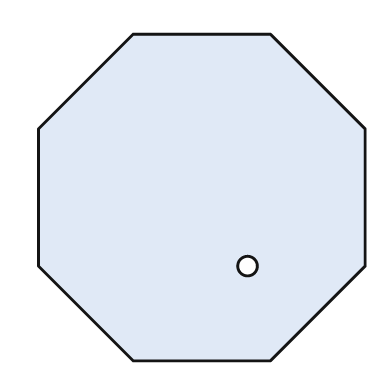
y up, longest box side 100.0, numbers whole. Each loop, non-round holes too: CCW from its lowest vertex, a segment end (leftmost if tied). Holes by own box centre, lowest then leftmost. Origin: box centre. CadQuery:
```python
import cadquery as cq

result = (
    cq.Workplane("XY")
    .moveTo(-21.0, -50.0)
    .lineTo(21.0, -50.0)
    .lineTo(50.0, -21.0)
    .lineTo(50.0, 21.0)
    .lineTo(21.0, 50.0)
    .lineTo(-21.0, 50.0)
    .lineTo(-50.0, 21.0)
    .lineTo(-50.0, -21.0)
    .close()
    .moveTo(14.0, -21.0)
    .circle(3.0)
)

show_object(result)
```